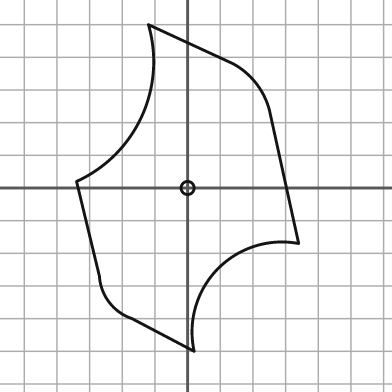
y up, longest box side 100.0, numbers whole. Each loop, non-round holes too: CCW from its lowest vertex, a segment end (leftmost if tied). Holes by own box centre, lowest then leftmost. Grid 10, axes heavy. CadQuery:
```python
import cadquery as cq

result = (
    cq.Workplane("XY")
    .moveTo(2.0, -50.0)
    .threePointArc((9.0, -25.0), (34.0, -17.0))
    .lineTo(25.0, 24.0)
    .threePointArc((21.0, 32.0), (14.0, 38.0))
    .lineTo(-12.0, 50.0)
    .threePointArc((-14.0, 22.0), (-34.0, 2.0))
    .lineTo(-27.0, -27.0)
    .threePointArc((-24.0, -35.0), (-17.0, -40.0))
    .close()
    .moveTo(0.0, 0.0)
    .circle(2.0)
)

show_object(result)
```